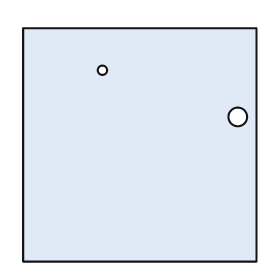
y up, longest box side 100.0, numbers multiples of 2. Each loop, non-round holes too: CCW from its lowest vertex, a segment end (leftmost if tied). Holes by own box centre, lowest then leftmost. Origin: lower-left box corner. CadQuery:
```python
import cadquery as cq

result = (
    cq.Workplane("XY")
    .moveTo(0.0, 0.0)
    .lineTo(100.0, 0.0)
    .lineTo(100.0, 100.0)
    .lineTo(0.0, 100.0)
    .close()
    .moveTo(92.0, 62.0)
    .circle(4.0)
    .moveTo(34.0, 82.0)
    .circle(2.0)
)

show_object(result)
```